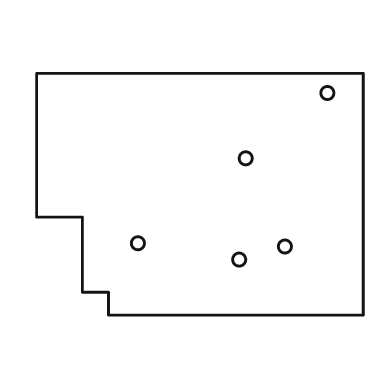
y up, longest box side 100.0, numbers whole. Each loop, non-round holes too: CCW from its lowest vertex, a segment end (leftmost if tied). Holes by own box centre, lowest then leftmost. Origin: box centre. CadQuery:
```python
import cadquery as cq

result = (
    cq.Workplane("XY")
    .moveTo(-28.0, -37.0)
    .lineTo(50.0, -37.0)
    .lineTo(50.0, 37.0)
    .lineTo(-50.0, 37.0)
    .lineTo(-50.0, -7.0)
    .lineTo(-36.0, -7.0)
    .lineTo(-36.0, -30.0)
    .lineTo(-28.0, -30.0)
    .close()
    .moveTo(12.0, -20.0)
    .circle(2.0)
    .moveTo(26.0, -16.0)
    .circle(2.0)
    .moveTo(-19.0, -15.0)
    .circle(2.0)
    .moveTo(14.0, 11.0)
    .circle(2.0)
    .moveTo(39.0, 31.0)
    .circle(2.0)
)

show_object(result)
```